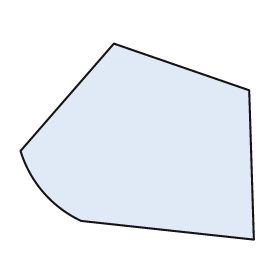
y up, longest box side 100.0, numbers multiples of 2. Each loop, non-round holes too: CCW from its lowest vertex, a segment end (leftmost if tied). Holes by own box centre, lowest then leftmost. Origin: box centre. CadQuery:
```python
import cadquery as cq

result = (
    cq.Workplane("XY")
    .moveTo(50.0, -42.0)
    .lineTo(48.0, 22.0)
    .lineTo(-10.0, 42.0)
    .lineTo(-50.0, -4.0)
    .threePointArc((-40.0, -22.0), (-24.0, -34.0))
    .close()
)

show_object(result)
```